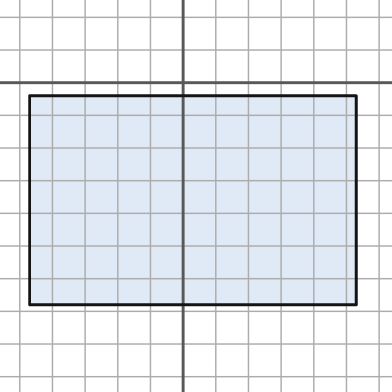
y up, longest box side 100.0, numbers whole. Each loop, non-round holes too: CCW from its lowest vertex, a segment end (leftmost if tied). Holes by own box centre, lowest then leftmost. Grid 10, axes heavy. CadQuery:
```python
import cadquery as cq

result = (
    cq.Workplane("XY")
    .moveTo(-47.0, -68.0)
    .lineTo(53.0, -68.0)
    .lineTo(53.0, -4.0)
    .lineTo(-47.0, -4.0)
    .close()
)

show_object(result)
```